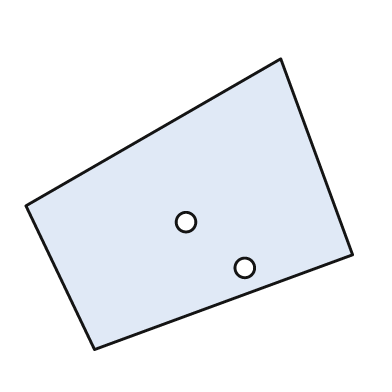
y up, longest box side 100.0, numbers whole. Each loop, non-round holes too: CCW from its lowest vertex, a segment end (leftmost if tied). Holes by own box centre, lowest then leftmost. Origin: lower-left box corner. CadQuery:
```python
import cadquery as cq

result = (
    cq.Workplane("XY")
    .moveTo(21.0, 0.0)
    .lineTo(100.0, 29.0)
    .lineTo(78.0, 89.0)
    .lineTo(0.0, 44.0)
    .close()
    .moveTo(67.0, 25.0)
    .circle(3.0)
    .moveTo(49.0, 39.0)
    .circle(3.0)
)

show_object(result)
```